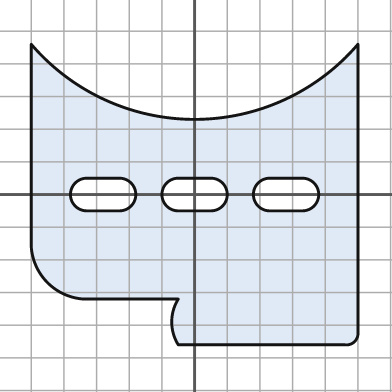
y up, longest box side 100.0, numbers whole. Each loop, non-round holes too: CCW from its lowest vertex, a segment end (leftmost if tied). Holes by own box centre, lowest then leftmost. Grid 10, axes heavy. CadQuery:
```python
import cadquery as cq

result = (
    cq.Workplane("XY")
    .moveTo(-5.0, -46.0)
    .lineTo(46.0, -46.0)
    .threePointArc((49.0, -45.0), (50.0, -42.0))
    .lineTo(50.0, 46.0)
    .threePointArc((0.0, 23.0), (-50.0, 46.0))
    .lineTo(-50.0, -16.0)
    .threePointArc((-45.0, -27.0), (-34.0, -32.0))
    .lineTo(-5.0, -32.0)
    .threePointArc((-7.0, -39.0), (-5.0, -46.0))
    .close()
    .moveTo(-33.0, -5.0)
    .lineTo(-23.0, -5.0)
    .threePointArc((-18.0, 0.0), (-23.0, 5.0))
    .lineTo(-33.0, 5.0)
    .threePointArc((-38.0, 0.0), (-33.0, -5.0))
    .close()
    .moveTo(-5.0, -5.0)
    .lineTo(5.0, -5.0)
    .threePointArc((10.0, 0.0), (5.0, 5.0))
    .lineTo(-5.0, 5.0)
    .threePointArc((-10.0, 0.0), (-5.0, -5.0))
    .close()
    .moveTo(23.0, -5.0)
    .lineTo(33.0, -5.0)
    .threePointArc((38.0, 0.0), (33.0, 5.0))
    .lineTo(23.0, 5.0)
    .threePointArc((18.0, 0.0), (23.0, -5.0))
    .close()
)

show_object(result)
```